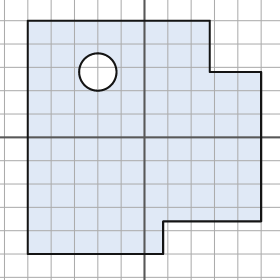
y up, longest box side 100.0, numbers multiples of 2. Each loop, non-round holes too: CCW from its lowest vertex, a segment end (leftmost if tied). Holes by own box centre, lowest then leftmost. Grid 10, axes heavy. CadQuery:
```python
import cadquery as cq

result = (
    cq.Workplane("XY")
    .moveTo(-50.0, -50.0)
    .lineTo(8.0, -50.0)
    .lineTo(8.0, -36.0)
    .lineTo(50.0, -36.0)
    .lineTo(50.0, 28.0)
    .lineTo(28.0, 28.0)
    .lineTo(28.0, 50.0)
    .lineTo(-50.0, 50.0)
    .close()
    .moveTo(-20.0, 28.0)
    .circle(8.0)
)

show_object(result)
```